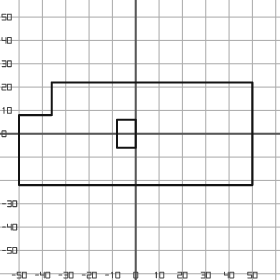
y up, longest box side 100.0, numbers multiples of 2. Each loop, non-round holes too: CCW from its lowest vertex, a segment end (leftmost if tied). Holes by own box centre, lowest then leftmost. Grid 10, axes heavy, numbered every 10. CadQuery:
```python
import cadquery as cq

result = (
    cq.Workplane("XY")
    .moveTo(-50.0, -22.0)
    .lineTo(50.0, -22.0)
    .lineTo(50.0, 22.0)
    .lineTo(-36.0, 22.0)
    .lineTo(-36.0, 8.0)
    .lineTo(-50.0, 8.0)
    .close()
    .moveTo(-8.0, -6.0)
    .lineTo(0.0, -6.0)
    .lineTo(0.0, 6.0)
    .lineTo(-8.0, 6.0)
    .close()
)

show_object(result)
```